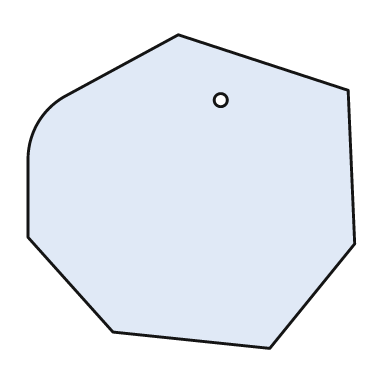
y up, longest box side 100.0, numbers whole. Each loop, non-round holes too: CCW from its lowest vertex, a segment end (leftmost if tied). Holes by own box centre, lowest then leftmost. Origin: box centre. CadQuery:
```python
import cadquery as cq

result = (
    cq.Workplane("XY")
    .moveTo(24.0, -48.0)
    .lineTo(50.0, -16.0)
    .lineTo(48.0, 31.0)
    .lineTo(-4.0, 48.0)
    .lineTo(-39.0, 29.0)
    .threePointArc((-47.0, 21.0), (-50.0, 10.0))
    .lineTo(-50.0, -14.0)
    .lineTo(-24.0, -43.0)
    .close()
    .moveTo(9.0, 28.0)
    .circle(2.0)
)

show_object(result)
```